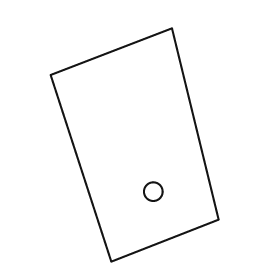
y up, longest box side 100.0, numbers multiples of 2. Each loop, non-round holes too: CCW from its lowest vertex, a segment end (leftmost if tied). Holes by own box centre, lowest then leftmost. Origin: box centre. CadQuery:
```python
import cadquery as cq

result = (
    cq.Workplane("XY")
    .moveTo(-10.0, -50.0)
    .lineTo(36.0, -32.0)
    .lineTo(16.0, 50.0)
    .lineTo(-36.0, 30.0)
    .close()
    .moveTo(8.0, -20.0)
    .circle(4.0)
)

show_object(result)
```